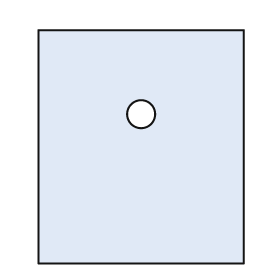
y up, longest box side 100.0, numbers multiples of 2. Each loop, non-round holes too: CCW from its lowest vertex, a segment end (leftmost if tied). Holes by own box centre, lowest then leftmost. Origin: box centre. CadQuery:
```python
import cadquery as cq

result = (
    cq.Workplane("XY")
    .moveTo(-44.0, -50.0)
    .lineTo(44.0, -50.0)
    .lineTo(44.0, 50.0)
    .lineTo(-44.0, 50.0)
    .close()
    .moveTo(0.0, 14.0)
    .circle(6.0)
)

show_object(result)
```